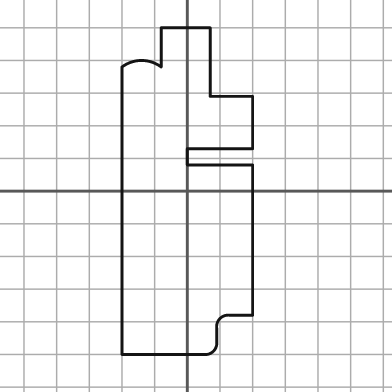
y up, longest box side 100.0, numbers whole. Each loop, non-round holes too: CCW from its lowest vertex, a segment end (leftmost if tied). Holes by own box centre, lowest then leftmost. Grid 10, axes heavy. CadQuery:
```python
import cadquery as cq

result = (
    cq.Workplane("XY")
    .moveTo(-20.0, -50.0)
    .lineTo(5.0, -50.0)
    .threePointArc((8.0, -49.0), (9.0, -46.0))
    .lineTo(9.0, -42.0)
    .threePointArc((10.0, -39.0), (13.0, -38.0))
    .lineTo(20.0, -38.0)
    .lineTo(20.0, 8.0)
    .lineTo(0.0, 8.0)
    .lineTo(0.0, 13.0)
    .lineTo(20.0, 13.0)
    .lineTo(20.0, 29.0)
    .lineTo(7.0, 29.0)
    .lineTo(7.0, 50.0)
    .lineTo(-8.0, 50.0)
    .lineTo(-8.0, 38.0)
    .threePointArc((-14.0, 40.0), (-20.0, 38.0))
    .close()
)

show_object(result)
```